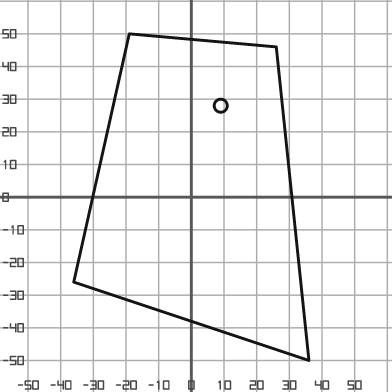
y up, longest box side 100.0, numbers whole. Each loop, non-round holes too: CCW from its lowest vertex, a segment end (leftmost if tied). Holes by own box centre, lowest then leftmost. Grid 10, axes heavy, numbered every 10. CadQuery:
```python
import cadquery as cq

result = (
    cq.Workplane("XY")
    .moveTo(36.0, -50.0)
    .lineTo(26.0, 46.0)
    .lineTo(-19.0, 50.0)
    .lineTo(-36.0, -26.0)
    .close()
    .moveTo(9.0, 28.0)
    .circle(2.0)
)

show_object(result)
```